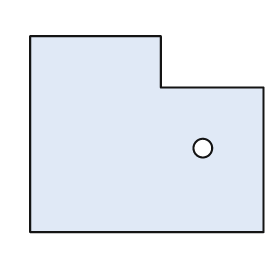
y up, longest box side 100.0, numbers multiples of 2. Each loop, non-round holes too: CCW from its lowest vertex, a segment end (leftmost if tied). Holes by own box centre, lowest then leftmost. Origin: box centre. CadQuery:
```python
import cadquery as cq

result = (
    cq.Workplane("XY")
    .moveTo(-50.0, -42.0)
    .lineTo(50.0, -42.0)
    .lineTo(50.0, 20.0)
    .lineTo(6.0, 20.0)
    .lineTo(6.0, 42.0)
    .lineTo(-50.0, 42.0)
    .close()
    .moveTo(24.0, -6.0)
    .circle(4.0)
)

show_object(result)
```